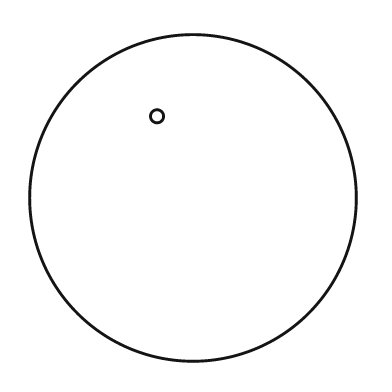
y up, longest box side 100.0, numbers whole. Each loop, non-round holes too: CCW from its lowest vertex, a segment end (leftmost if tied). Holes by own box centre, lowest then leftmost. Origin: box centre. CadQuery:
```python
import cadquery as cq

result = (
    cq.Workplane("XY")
    .moveTo(0.0, 0.0)
    .circle(50.0)
    .moveTo(-11.0, 25.0)
    .circle(2.0)
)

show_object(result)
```